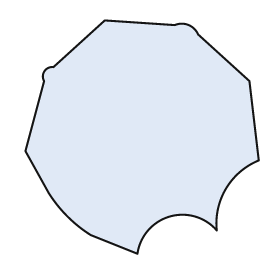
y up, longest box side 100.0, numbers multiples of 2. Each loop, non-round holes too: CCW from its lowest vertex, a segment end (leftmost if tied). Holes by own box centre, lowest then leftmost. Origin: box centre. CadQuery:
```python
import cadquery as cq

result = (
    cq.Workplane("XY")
    .moveTo(-2.0, -50.0)
    .threePointArc((12.0, -34.0), (32.0, -40.0))
    .threePointArc((36.0, -22.0), (50.0, -10.0))
    .lineTo(46.0, 24.0)
    .lineTo(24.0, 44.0)
    .threePointArc((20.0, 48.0), (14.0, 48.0))
    .lineTo(-16.0, 50.0)
    .lineTo(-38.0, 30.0)
    .threePointArc((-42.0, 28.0), (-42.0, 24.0))
    .lineTo(-50.0, -6.0)
    .lineTo(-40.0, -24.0)
    .threePointArc((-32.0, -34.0), (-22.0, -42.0))
    .close()
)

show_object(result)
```